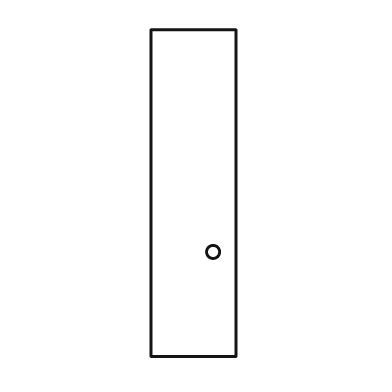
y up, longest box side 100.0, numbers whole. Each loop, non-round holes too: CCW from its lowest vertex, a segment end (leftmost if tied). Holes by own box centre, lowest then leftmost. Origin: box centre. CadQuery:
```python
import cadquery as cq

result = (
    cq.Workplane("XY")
    .moveTo(-13.0, -50.0)
    .lineTo(13.0, -50.0)
    .lineTo(13.0, 50.0)
    .lineTo(-13.0, 50.0)
    .close()
    .moveTo(6.0, -18.0)
    .circle(2.0)
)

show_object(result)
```